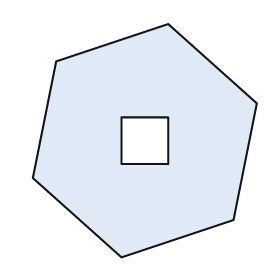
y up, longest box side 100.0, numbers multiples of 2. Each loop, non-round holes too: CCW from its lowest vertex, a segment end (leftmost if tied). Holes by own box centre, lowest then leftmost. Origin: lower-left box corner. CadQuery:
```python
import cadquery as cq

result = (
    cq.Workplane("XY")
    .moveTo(38.0, 0.0)
    .lineTo(86.0, 16.0)
    .lineTo(96.0, 66.0)
    .lineTo(58.0, 100.0)
    .lineTo(10.0, 84.0)
    .lineTo(0.0, 34.0)
    .close()
    .moveTo(38.0, 40.0)
    .lineTo(58.0, 40.0)
    .lineTo(58.0, 60.0)
    .lineTo(38.0, 60.0)
    .close()
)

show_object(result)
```